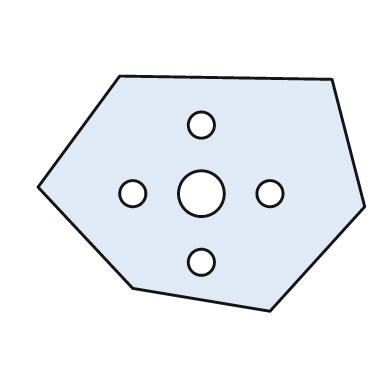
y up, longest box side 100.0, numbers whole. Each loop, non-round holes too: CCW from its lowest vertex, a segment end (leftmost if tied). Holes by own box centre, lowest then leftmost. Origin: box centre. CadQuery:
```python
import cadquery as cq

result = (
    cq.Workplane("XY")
    .moveTo(21.0, -36.0)
    .lineTo(50.0, -4.0)
    .lineTo(40.0, 35.0)
    .lineTo(-25.0, 36.0)
    .lineTo(-50.0, 2.0)
    .lineTo(-21.0, -29.0)
    .close()
    .moveTo(0.0, -21.0)
    .circle(4.0)
    .moveTo(-21.0, 0.0)
    .circle(4.0)
    .moveTo(0.0, 0.0)
    .circle(7.0)
    .moveTo(21.0, 0.0)
    .circle(4.0)
    .moveTo(0.0, 21.0)
    .circle(4.0)
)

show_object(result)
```